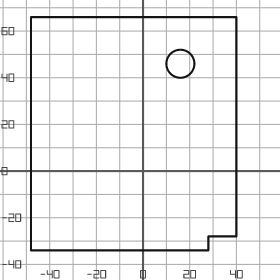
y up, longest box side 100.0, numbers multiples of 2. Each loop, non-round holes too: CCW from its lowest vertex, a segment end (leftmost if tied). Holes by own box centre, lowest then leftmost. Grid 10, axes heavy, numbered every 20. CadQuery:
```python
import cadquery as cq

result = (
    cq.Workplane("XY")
    .moveTo(-48.0, -34.0)
    .lineTo(28.0, -34.0)
    .lineTo(28.0, -28.0)
    .lineTo(40.0, -28.0)
    .lineTo(40.0, 66.0)
    .lineTo(-48.0, 66.0)
    .close()
    .moveTo(16.0, 46.0)
    .circle(6.0)
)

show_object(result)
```